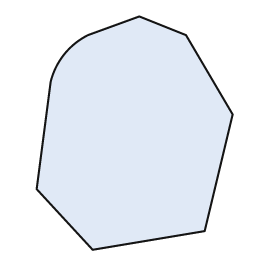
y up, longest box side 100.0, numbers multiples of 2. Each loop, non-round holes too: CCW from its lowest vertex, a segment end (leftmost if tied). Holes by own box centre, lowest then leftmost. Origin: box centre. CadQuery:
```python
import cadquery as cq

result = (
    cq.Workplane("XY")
    .moveTo(-18.0, -50.0)
    .lineTo(30.0, -42.0)
    .lineTo(42.0, 8.0)
    .lineTo(22.0, 42.0)
    .lineTo(2.0, 50.0)
    .lineTo(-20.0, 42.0)
    .threePointArc((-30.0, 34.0), (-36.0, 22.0))
    .lineTo(-42.0, -24.0)
    .close()
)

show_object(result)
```